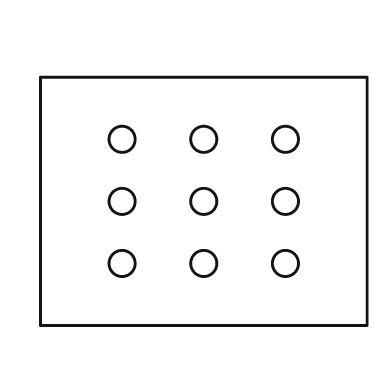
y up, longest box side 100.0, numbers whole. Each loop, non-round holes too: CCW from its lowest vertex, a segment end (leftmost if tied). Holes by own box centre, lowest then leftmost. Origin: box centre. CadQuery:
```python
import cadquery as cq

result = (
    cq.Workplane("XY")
    .moveTo(-50.0, -38.0)
    .lineTo(50.0, -38.0)
    .lineTo(50.0, 38.0)
    .lineTo(-50.0, 38.0)
    .close()
    .moveTo(-25.0, -19.0)
    .circle(4.0)
    .moveTo(0.0, -19.0)
    .circle(4.0)
    .moveTo(25.0, -19.0)
    .circle(4.0)
    .moveTo(-25.0, 0.0)
    .circle(4.0)
    .moveTo(0.0, 0.0)
    .circle(4.0)
    .moveTo(25.0, 0.0)
    .circle(4.0)
    .moveTo(-25.0, 19.0)
    .circle(4.0)
    .moveTo(0.0, 19.0)
    .circle(4.0)
    .moveTo(25.0, 19.0)
    .circle(4.0)
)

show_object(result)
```